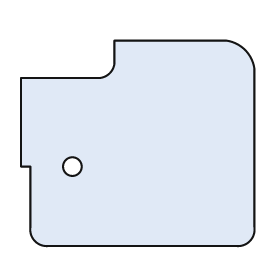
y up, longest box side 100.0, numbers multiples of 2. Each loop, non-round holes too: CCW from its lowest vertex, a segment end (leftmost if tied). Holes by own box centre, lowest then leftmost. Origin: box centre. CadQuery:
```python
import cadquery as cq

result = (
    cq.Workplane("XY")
    .moveTo(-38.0, -44.0)
    .lineTo(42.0, -44.0)
    .threePointArc((48.0, -42.0), (50.0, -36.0))
    .lineTo(50.0, 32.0)
    .threePointArc((46.0, 40.0), (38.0, 44.0))
    .lineTo(-10.0, 44.0)
    .lineTo(-10.0, 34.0)
    .threePointArc((-12.0, 30.0), (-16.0, 28.0))
    .lineTo(-50.0, 28.0)
    .lineTo(-50.0, -10.0)
    .lineTo(-46.0, -10.0)
    .lineTo(-46.0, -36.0)
    .threePointArc((-44.0, -42.0), (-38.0, -44.0))
    .close()
    .moveTo(-28.0, -10.0)
    .circle(4.0)
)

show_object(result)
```